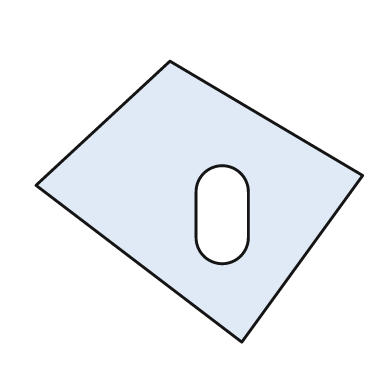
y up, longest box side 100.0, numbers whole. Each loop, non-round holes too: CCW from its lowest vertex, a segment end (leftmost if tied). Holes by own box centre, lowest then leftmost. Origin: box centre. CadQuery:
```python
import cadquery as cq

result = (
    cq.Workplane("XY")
    .moveTo(13.0, -43.0)
    .lineTo(50.0, 8.0)
    .lineTo(-9.0, 43.0)
    .lineTo(-50.0, 5.0)
    .close()
    .moveTo(-1.0, -11.0)
    .threePointArc((7.0, -19.0), (15.0, -11.0))
    .lineTo(15.0, 3.0)
    .threePointArc((7.0, 11.0), (-1.0, 3.0))
    .close()
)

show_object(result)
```